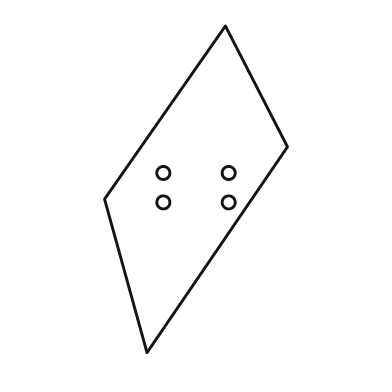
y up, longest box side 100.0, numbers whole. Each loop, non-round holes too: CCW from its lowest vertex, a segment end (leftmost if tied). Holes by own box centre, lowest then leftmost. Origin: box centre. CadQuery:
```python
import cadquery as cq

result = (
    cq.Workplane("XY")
    .moveTo(-15.0, -50.0)
    .lineTo(28.0, 13.0)
    .lineTo(9.0, 50.0)
    .lineTo(-28.0, -3.0)
    .close()
    .moveTo(-10.0, -4.0)
    .circle(2.0)
    .moveTo(10.0, -4.0)
    .circle(2.0)
    .moveTo(-10.0, 5.0)
    .circle(2.0)
    .moveTo(10.0, 5.0)
    .circle(2.0)
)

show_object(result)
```